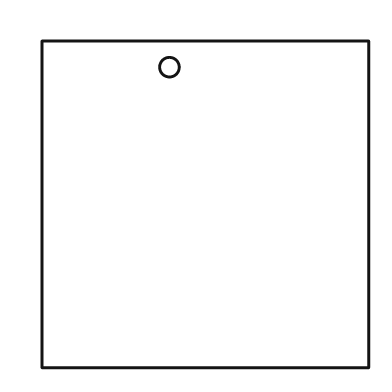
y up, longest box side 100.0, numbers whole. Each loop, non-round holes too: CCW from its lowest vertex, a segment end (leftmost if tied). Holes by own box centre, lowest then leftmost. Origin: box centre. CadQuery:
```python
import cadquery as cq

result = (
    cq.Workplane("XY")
    .moveTo(-50.0, -50.0)
    .lineTo(50.0, -50.0)
    .lineTo(50.0, 50.0)
    .lineTo(-50.0, 50.0)
    .close()
    .moveTo(-11.0, 42.0)
    .circle(3.0)
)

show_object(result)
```